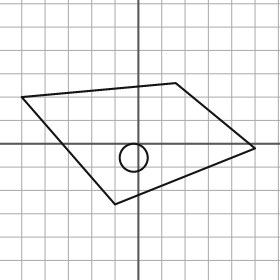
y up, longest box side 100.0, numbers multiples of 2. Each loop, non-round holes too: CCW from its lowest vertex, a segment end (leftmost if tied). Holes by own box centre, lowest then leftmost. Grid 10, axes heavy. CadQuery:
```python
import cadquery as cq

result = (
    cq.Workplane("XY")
    .moveTo(-10.0, -26.0)
    .lineTo(50.0, -2.0)
    .lineTo(16.0, 26.0)
    .lineTo(-50.0, 20.0)
    .close()
    .moveTo(-2.0, -6.0)
    .circle(6.0)
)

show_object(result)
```